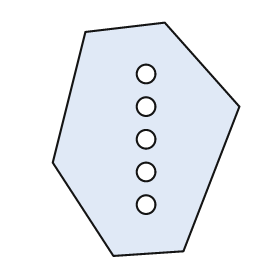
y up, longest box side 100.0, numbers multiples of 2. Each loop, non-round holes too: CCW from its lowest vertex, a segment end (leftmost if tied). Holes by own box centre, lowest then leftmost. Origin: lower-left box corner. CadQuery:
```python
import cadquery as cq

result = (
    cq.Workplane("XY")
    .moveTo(26.0, 0.0)
    .lineTo(56.0, 2.0)
    .lineTo(80.0, 64.0)
    .lineTo(48.0, 100.0)
    .lineTo(14.0, 96.0)
    .lineTo(0.0, 40.0)
    .close()
    .moveTo(40.0, 22.0)
    .circle(4.0)
    .moveTo(40.0, 36.0)
    .circle(4.0)
    .moveTo(40.0, 50.0)
    .circle(4.0)
    .moveTo(40.0, 64.0)
    .circle(4.0)
    .moveTo(40.0, 78.0)
    .circle(4.0)
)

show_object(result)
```